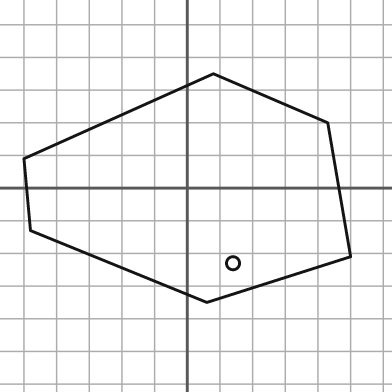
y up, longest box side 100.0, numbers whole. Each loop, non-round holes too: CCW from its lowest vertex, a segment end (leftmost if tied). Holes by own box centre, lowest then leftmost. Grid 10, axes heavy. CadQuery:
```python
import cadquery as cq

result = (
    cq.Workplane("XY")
    .moveTo(6.0, -35.0)
    .lineTo(50.0, -21.0)
    .lineTo(43.0, 20.0)
    .lineTo(8.0, 35.0)
    .lineTo(-50.0, 9.0)
    .lineTo(-48.0, -13.0)
    .close()
    .moveTo(14.0, -23.0)
    .circle(2.0)
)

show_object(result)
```